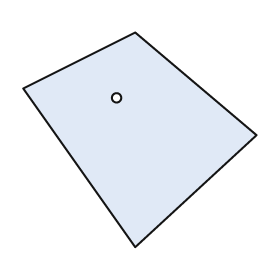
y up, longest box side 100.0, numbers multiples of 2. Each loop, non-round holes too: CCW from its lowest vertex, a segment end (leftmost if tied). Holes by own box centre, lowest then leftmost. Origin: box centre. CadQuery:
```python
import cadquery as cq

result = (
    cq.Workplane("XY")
    .moveTo(-2.0, -46.0)
    .lineTo(50.0, 2.0)
    .lineTo(-2.0, 46.0)
    .lineTo(-50.0, 22.0)
    .close()
    .moveTo(-10.0, 18.0)
    .circle(2.0)
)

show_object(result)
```